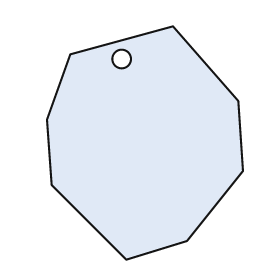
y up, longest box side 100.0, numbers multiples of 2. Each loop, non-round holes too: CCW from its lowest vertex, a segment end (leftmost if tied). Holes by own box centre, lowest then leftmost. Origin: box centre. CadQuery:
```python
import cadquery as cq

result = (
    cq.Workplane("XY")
    .moveTo(-8.0, -50.0)
    .lineTo(18.0, -42.0)
    .lineTo(42.0, -12.0)
    .lineTo(40.0, 18.0)
    .lineTo(12.0, 50.0)
    .lineTo(-32.0, 38.0)
    .lineTo(-42.0, 10.0)
    .lineTo(-40.0, -18.0)
    .close()
    .moveTo(-10.0, 36.0)
    .circle(4.0)
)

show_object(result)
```